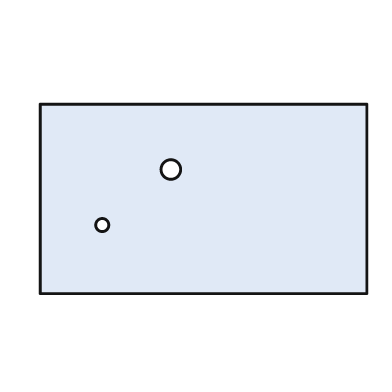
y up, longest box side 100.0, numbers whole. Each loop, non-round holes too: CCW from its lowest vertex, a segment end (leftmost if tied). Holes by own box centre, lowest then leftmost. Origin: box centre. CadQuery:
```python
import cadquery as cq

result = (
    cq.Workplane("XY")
    .moveTo(-50.0, -29.0)
    .lineTo(50.0, -29.0)
    .lineTo(50.0, 29.0)
    .lineTo(-50.0, 29.0)
    .close()
    .moveTo(-31.0, -8.0)
    .circle(2.0)
    .moveTo(-10.0, 9.0)
    .circle(3.0)
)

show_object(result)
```